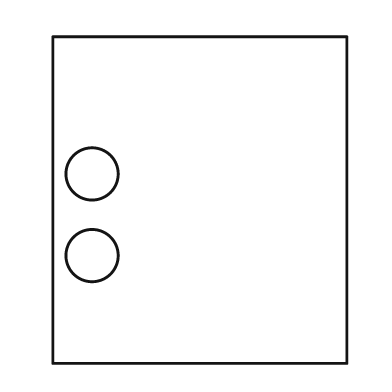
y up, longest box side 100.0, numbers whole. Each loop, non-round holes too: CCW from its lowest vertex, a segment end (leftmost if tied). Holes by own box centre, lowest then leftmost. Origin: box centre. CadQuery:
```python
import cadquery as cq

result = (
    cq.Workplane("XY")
    .moveTo(-45.0, -50.0)
    .lineTo(45.0, -50.0)
    .lineTo(45.0, 50.0)
    .lineTo(-45.0, 50.0)
    .close()
    .moveTo(-33.0, -17.0)
    .circle(8.0)
    .moveTo(-33.0, 8.0)
    .circle(8.0)
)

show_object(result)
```